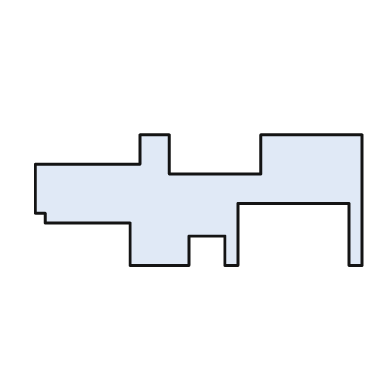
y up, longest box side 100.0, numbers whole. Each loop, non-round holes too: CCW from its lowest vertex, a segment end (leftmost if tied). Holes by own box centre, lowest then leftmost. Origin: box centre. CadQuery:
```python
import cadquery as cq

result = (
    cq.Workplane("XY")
    .moveTo(-21.0, -20.0)
    .lineTo(-3.0, -20.0)
    .lineTo(-3.0, -11.0)
    .lineTo(8.0, -11.0)
    .lineTo(8.0, -20.0)
    .lineTo(12.0, -20.0)
    .lineTo(12.0, -1.0)
    .lineTo(46.0, -1.0)
    .lineTo(46.0, -20.0)
    .lineTo(50.0, -20.0)
    .lineTo(50.0, 20.0)
    .lineTo(19.0, 20.0)
    .lineTo(19.0, 8.0)
    .lineTo(-9.0, 8.0)
    .lineTo(-9.0, 20.0)
    .lineTo(-18.0, 20.0)
    .lineTo(-18.0, 11.0)
    .lineTo(-50.0, 11.0)
    .lineTo(-50.0, -4.0)
    .lineTo(-47.0, -4.0)
    .lineTo(-47.0, -7.0)
    .lineTo(-21.0, -7.0)
    .close()
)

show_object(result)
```